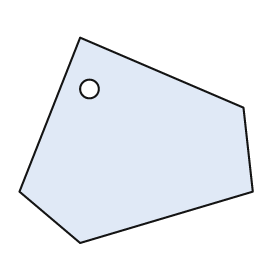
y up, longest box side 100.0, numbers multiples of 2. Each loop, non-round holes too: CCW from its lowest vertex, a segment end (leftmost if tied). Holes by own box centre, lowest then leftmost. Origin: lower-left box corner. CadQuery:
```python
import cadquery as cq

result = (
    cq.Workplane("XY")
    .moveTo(26.0, 0.0)
    .lineTo(100.0, 22.0)
    .lineTo(96.0, 58.0)
    .lineTo(26.0, 88.0)
    .lineTo(0.0, 22.0)
    .close()
    .moveTo(30.0, 66.0)
    .circle(4.0)
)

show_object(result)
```